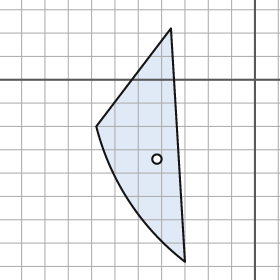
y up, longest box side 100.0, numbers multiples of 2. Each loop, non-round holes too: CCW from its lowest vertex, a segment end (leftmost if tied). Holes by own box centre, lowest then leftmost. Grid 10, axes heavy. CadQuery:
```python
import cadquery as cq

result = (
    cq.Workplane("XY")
    .moveTo(-30.0, -78.0)
    .lineTo(-36.0, 22.0)
    .lineTo(-68.0, -20.0)
    .threePointArc((-54.0, -52.0), (-30.0, -78.0))
    .close()
    .moveTo(-42.0, -34.0)
    .circle(2.0)
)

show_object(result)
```